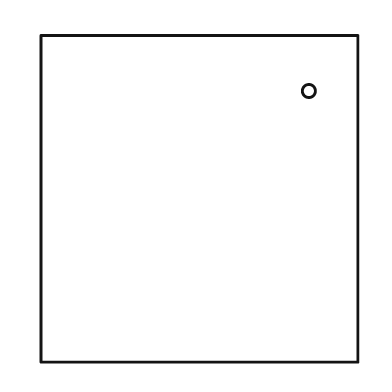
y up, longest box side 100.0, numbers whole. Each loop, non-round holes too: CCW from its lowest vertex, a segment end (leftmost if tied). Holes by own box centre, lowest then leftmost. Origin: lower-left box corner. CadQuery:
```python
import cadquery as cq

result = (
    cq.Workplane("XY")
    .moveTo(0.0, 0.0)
    .lineTo(97.0, 0.0)
    .lineTo(97.0, 100.0)
    .lineTo(0.0, 100.0)
    .close()
    .moveTo(82.0, 83.0)
    .circle(2.0)
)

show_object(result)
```